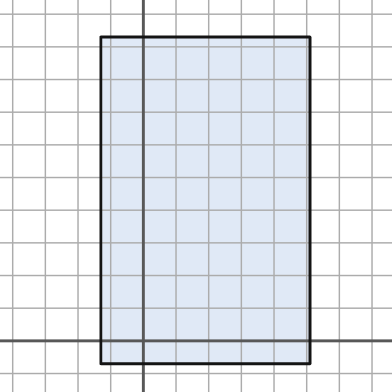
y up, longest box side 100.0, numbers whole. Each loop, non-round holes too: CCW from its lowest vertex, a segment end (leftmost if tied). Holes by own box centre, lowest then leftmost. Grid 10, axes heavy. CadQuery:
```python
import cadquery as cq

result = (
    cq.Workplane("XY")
    .moveTo(-13.0, -7.0)
    .lineTo(51.0, -7.0)
    .lineTo(51.0, 93.0)
    .lineTo(-13.0, 93.0)
    .close()
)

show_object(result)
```